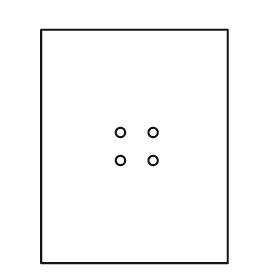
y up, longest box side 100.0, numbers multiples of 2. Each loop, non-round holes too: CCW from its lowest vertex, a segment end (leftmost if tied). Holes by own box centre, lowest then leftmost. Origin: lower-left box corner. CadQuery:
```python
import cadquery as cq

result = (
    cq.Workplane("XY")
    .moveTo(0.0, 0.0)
    .lineTo(80.0, 0.0)
    .lineTo(80.0, 100.0)
    .lineTo(0.0, 100.0)
    .close()
    .moveTo(34.0, 44.0)
    .circle(2.0)
    .moveTo(48.0, 44.0)
    .circle(2.0)
    .moveTo(34.0, 56.0)
    .circle(2.0)
    .moveTo(48.0, 56.0)
    .circle(2.0)
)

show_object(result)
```